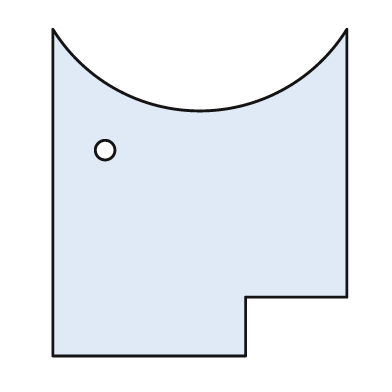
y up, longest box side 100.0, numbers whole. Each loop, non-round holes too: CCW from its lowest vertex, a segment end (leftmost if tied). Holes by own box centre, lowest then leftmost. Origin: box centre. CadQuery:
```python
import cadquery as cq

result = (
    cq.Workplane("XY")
    .moveTo(-45.0, -50.0)
    .lineTo(14.0, -50.0)
    .lineTo(14.0, -32.0)
    .lineTo(45.0, -32.0)
    .lineTo(45.0, 50.0)
    .threePointArc((0.0, 25.0), (-45.0, 50.0))
    .close()
    .moveTo(-29.0, 13.0)
    .circle(3.0)
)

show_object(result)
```